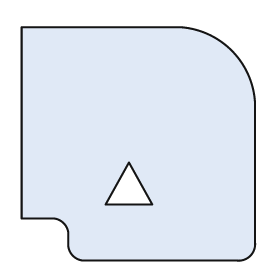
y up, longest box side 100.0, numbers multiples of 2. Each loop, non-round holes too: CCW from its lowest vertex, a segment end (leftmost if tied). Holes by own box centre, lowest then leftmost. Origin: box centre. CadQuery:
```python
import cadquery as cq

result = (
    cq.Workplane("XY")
    .moveTo(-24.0, -50.0)
    .lineTo(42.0, -50.0)
    .threePointArc((48.0, -48.0), (50.0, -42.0))
    .lineTo(50.0, 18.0)
    .threePointArc((40.0, 40.0), (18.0, 50.0))
    .lineTo(-50.0, 50.0)
    .lineTo(-50.0, -32.0)
    .lineTo(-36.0, -32.0)
    .threePointArc((-32.0, -34.0), (-30.0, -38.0))
    .lineTo(-30.0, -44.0)
    .threePointArc((-28.0, -48.0), (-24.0, -50.0))
    .close()
    .moveTo(-14.0, -26.0)
    .lineTo(6.0, -26.0)
    .lineTo(-4.0, -8.0)
    .close()
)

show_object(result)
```